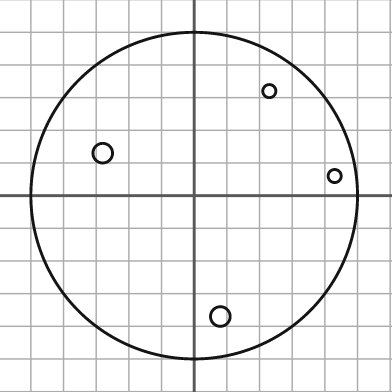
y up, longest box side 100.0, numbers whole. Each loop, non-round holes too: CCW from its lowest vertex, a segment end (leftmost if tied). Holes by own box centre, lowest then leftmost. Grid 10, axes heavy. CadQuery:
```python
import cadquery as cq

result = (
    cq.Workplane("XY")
    .moveTo(0.0, 0.0)
    .circle(50.0)
    .moveTo(8.0, -37.0)
    .circle(3.0)
    .moveTo(43.0, 6.0)
    .circle(2.0)
    .moveTo(-28.0, 13.0)
    .circle(3.0)
    .moveTo(23.0, 32.0)
    .circle(2.0)
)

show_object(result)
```